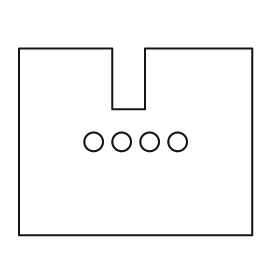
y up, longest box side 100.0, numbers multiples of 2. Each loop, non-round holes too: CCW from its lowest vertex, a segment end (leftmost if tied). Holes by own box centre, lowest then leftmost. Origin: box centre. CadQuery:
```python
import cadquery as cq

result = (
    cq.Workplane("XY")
    .moveTo(-50.0, -40.0)
    .lineTo(50.0, -40.0)
    .lineTo(50.0, 40.0)
    .lineTo(4.0, 40.0)
    .lineTo(4.0, 14.0)
    .lineTo(-10.0, 14.0)
    .lineTo(-10.0, 40.0)
    .lineTo(-50.0, 40.0)
    .close()
    .moveTo(-18.0, 0.0)
    .circle(4.0)
    .moveTo(-6.0, 0.0)
    .circle(4.0)
    .moveTo(6.0, 0.0)
    .circle(4.0)
    .moveTo(18.0, 0.0)
    .circle(4.0)
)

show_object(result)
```